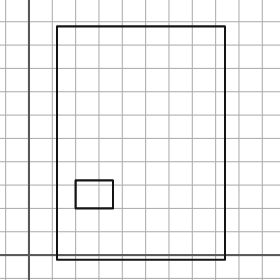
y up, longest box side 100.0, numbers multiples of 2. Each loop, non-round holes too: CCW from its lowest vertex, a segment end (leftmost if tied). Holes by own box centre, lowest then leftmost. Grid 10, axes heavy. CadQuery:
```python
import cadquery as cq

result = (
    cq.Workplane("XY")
    .moveTo(12.0, -2.0)
    .lineTo(84.0, -2.0)
    .lineTo(84.0, 98.0)
    .lineTo(12.0, 98.0)
    .close()
    .moveTo(20.0, 20.0)
    .lineTo(36.0, 20.0)
    .lineTo(36.0, 32.0)
    .lineTo(20.0, 32.0)
    .close()
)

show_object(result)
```